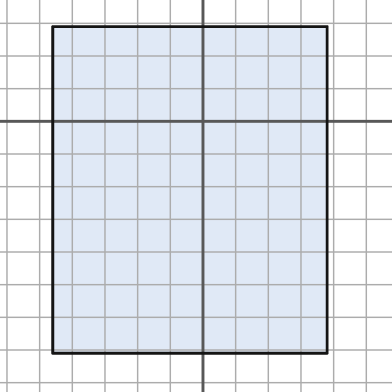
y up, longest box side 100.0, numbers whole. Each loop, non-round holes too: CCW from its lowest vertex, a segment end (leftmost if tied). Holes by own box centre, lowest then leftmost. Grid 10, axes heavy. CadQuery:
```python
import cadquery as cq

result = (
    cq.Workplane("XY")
    .moveTo(-46.0, -71.0)
    .lineTo(38.0, -71.0)
    .lineTo(38.0, 29.0)
    .lineTo(-46.0, 29.0)
    .close()
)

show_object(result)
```